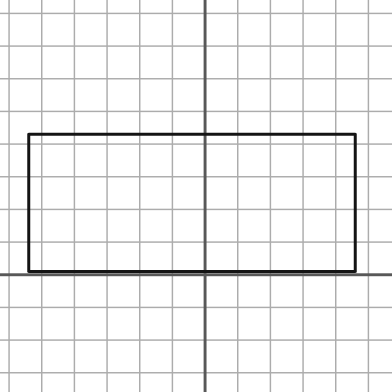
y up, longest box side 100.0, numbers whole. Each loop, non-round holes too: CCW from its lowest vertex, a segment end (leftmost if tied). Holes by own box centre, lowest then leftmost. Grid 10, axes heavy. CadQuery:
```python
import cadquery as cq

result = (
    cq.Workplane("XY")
    .moveTo(-54.0, 1.0)
    .lineTo(46.0, 1.0)
    .lineTo(46.0, 43.0)
    .lineTo(-54.0, 43.0)
    .close()
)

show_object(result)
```